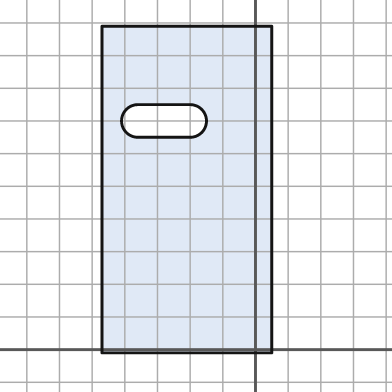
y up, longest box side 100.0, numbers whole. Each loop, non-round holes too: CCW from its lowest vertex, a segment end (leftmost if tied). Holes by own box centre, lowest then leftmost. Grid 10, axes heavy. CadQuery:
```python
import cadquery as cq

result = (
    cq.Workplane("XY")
    .moveTo(-47.0, -1.0)
    .lineTo(5.0, -1.0)
    .lineTo(5.0, 99.0)
    .lineTo(-47.0, 99.0)
    .close()
    .moveTo(-36.0, 65.0)
    .lineTo(-20.0, 65.0)
    .threePointArc((-15.0, 70.0), (-20.0, 75.0))
    .lineTo(-36.0, 75.0)
    .threePointArc((-41.0, 70.0), (-36.0, 65.0))
    .close()
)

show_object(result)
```